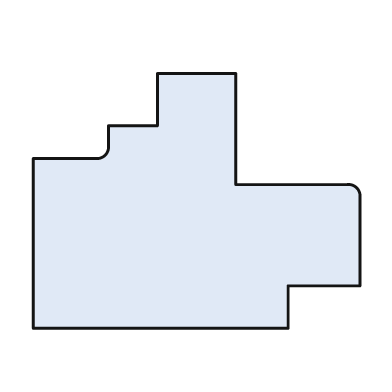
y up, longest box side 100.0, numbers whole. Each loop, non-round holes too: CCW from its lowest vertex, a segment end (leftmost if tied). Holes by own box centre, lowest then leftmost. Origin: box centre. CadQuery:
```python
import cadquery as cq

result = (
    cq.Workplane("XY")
    .moveTo(-50.0, -39.0)
    .lineTo(28.0, -39.0)
    .lineTo(28.0, -26.0)
    .lineTo(50.0, -26.0)
    .lineTo(50.0, 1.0)
    .threePointArc((49.0, 4.0), (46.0, 5.0))
    .lineTo(12.0, 5.0)
    .lineTo(12.0, 39.0)
    .lineTo(-12.0, 39.0)
    .lineTo(-12.0, 23.0)
    .lineTo(-27.0, 23.0)
    .lineTo(-27.0, 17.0)
    .threePointArc((-28.0, 14.0), (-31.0, 13.0))
    .lineTo(-50.0, 13.0)
    .close()
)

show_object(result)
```